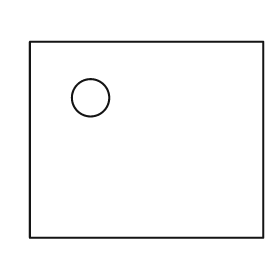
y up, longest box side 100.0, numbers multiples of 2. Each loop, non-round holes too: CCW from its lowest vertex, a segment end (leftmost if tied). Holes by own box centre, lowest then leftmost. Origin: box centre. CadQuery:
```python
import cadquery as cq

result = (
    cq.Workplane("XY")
    .moveTo(-50.0, -42.0)
    .lineTo(50.0, -42.0)
    .lineTo(50.0, 42.0)
    .lineTo(-50.0, 42.0)
    .close()
    .moveTo(-24.0, 18.0)
    .circle(8.0)
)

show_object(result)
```